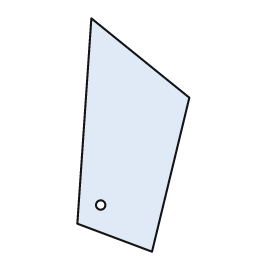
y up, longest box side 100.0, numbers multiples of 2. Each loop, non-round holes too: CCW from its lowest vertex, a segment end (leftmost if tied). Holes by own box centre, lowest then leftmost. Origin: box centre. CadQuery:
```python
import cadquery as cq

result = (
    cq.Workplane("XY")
    .moveTo(8.0, -50.0)
    .lineTo(24.0, 16.0)
    .lineTo(-18.0, 50.0)
    .lineTo(-24.0, -38.0)
    .close()
    .moveTo(-14.0, -30.0)
    .circle(2.0)
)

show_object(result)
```